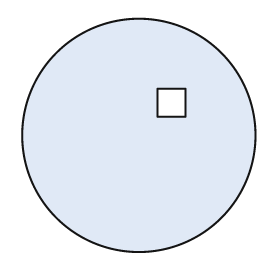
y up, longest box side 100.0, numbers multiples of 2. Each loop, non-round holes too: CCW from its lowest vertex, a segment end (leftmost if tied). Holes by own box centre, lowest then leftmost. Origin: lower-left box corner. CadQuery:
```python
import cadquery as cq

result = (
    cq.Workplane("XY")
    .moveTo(50.0, 50.0)
    .circle(50.0)
    .moveTo(58.0, 58.0)
    .lineTo(70.0, 58.0)
    .lineTo(70.0, 70.0)
    .lineTo(58.0, 70.0)
    .close()
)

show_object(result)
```